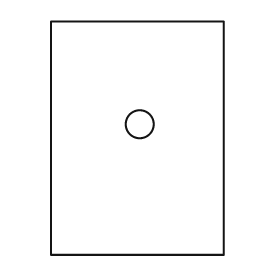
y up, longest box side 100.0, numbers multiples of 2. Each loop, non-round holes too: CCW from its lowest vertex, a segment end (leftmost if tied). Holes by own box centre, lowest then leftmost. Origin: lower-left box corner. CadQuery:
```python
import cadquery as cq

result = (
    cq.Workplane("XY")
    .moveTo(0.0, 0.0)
    .lineTo(74.0, 0.0)
    .lineTo(74.0, 100.0)
    .lineTo(0.0, 100.0)
    .close()
    .moveTo(38.0, 56.0)
    .circle(6.0)
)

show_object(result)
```